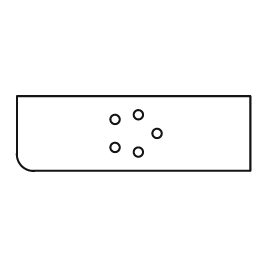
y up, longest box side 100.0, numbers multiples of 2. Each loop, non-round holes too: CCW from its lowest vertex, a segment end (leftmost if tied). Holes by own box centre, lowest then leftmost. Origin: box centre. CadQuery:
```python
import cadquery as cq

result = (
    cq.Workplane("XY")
    .moveTo(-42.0, -16.0)
    .lineTo(50.0, -16.0)
    .lineTo(50.0, 16.0)
    .lineTo(-50.0, 16.0)
    .lineTo(-50.0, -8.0)
    .threePointArc((-48.0, -14.0), (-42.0, -16.0))
    .close()
    .moveTo(2.0, -8.0)
    .circle(2.0)
    .moveTo(-8.0, -6.0)
    .circle(2.0)
    .moveTo(10.0, 0.0)
    .circle(2.0)
    .moveTo(-8.0, 6.0)
    .circle(2.0)
    .moveTo(2.0, 8.0)
    .circle(2.0)
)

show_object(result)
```